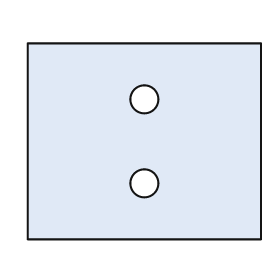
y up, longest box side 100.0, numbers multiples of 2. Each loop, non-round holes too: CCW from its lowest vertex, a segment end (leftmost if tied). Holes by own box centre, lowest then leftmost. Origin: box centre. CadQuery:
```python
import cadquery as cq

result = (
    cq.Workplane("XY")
    .moveTo(-50.0, -42.0)
    .lineTo(50.0, -42.0)
    .lineTo(50.0, 42.0)
    .lineTo(-50.0, 42.0)
    .close()
    .moveTo(0.0, -18.0)
    .circle(6.0)
    .moveTo(0.0, 18.0)
    .circle(6.0)
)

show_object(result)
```